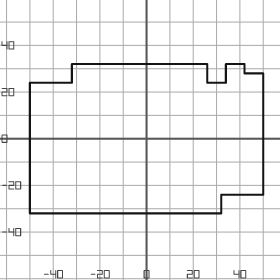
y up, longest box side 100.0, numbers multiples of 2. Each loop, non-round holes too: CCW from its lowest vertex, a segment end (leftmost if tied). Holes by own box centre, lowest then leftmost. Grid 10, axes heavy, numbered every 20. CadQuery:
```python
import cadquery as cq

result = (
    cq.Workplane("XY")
    .moveTo(-50.0, -32.0)
    .lineTo(32.0, -32.0)
    .lineTo(32.0, -24.0)
    .lineTo(50.0, -24.0)
    .lineTo(50.0, 28.0)
    .lineTo(42.0, 28.0)
    .lineTo(42.0, 32.0)
    .lineTo(34.0, 32.0)
    .lineTo(34.0, 24.0)
    .lineTo(26.0, 24.0)
    .lineTo(26.0, 32.0)
    .lineTo(-32.0, 32.0)
    .lineTo(-32.0, 24.0)
    .lineTo(-50.0, 24.0)
    .close()
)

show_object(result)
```